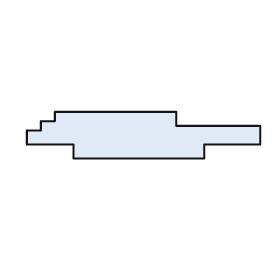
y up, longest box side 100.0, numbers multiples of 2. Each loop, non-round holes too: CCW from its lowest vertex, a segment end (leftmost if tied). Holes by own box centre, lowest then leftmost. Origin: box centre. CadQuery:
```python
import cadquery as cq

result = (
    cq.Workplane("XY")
    .moveTo(-30.0, -10.0)
    .lineTo(26.0, -10.0)
    .lineTo(26.0, -4.0)
    .lineTo(50.0, -4.0)
    .lineTo(50.0, 4.0)
    .lineTo(14.0, 4.0)
    .lineTo(14.0, 10.0)
    .lineTo(-38.0, 10.0)
    .lineTo(-38.0, 6.0)
    .lineTo(-44.0, 6.0)
    .lineTo(-44.0, 2.0)
    .lineTo(-50.0, 2.0)
    .lineTo(-50.0, -4.0)
    .lineTo(-30.0, -4.0)
    .close()
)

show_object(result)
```